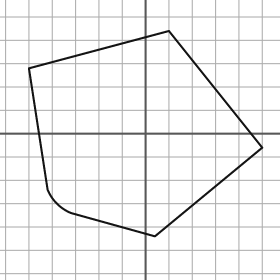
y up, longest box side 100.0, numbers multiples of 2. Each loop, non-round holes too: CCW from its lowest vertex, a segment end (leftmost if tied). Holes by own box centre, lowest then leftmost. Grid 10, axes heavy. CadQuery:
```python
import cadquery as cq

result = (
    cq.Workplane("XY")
    .moveTo(4.0, -44.0)
    .lineTo(50.0, -6.0)
    .lineTo(10.0, 44.0)
    .lineTo(-50.0, 28.0)
    .lineTo(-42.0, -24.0)
    .threePointArc((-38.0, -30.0), (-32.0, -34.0))
    .close()
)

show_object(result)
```